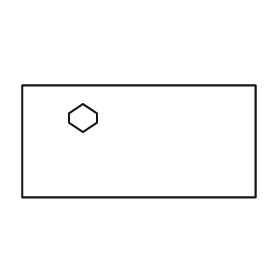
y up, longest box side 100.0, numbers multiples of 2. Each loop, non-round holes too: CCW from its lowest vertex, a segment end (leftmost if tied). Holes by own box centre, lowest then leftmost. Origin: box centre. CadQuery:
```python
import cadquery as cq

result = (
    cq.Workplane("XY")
    .moveTo(-50.0, -24.0)
    .lineTo(50.0, -24.0)
    .lineTo(50.0, 24.0)
    .lineTo(-50.0, 24.0)
    .close()
    .moveTo(-24.0, 4.0)
    .lineTo(-18.0, 8.0)
    .lineTo(-18.0, 12.0)
    .lineTo(-24.0, 16.0)
    .lineTo(-30.0, 12.0)
    .lineTo(-30.0, 8.0)
    .close()
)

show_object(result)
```